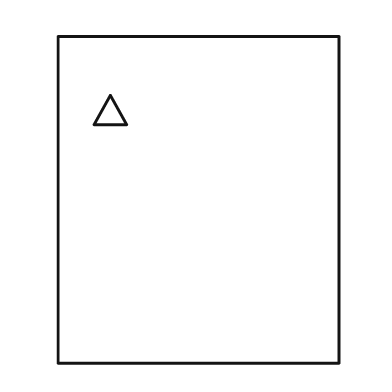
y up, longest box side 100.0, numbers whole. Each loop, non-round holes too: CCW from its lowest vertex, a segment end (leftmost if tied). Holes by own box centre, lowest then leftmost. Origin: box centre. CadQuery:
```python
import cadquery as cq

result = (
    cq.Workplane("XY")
    .moveTo(-43.0, -50.0)
    .lineTo(43.0, -50.0)
    .lineTo(43.0, 50.0)
    .lineTo(-43.0, 50.0)
    .close()
    .moveTo(-32.0, 23.0)
    .lineTo(-22.0, 23.0)
    .lineTo(-27.0, 32.0)
    .close()
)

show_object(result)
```